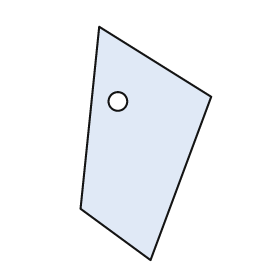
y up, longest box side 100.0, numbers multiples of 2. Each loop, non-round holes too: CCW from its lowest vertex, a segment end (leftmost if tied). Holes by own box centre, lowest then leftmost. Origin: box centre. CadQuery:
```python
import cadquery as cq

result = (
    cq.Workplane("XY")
    .moveTo(2.0, -50.0)
    .lineTo(28.0, 20.0)
    .lineTo(-20.0, 50.0)
    .lineTo(-28.0, -28.0)
    .close()
    .moveTo(-12.0, 18.0)
    .circle(4.0)
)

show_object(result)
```